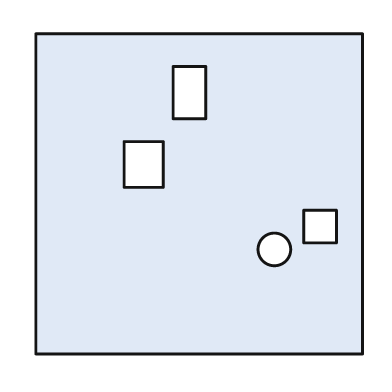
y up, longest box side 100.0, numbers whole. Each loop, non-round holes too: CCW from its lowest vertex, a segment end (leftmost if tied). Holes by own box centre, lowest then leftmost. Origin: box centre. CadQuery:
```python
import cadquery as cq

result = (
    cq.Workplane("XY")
    .moveTo(-50.0, -49.0)
    .lineTo(50.0, -49.0)
    .lineTo(50.0, 49.0)
    .lineTo(-50.0, 49.0)
    .close()
    .moveTo(23.0, -17.0)
    .circle(5.0)
    .moveTo(32.0, -15.0)
    .lineTo(42.0, -15.0)
    .lineTo(42.0, -5.0)
    .lineTo(32.0, -5.0)
    .close()
    .moveTo(-23.0, 2.0)
    .lineTo(-11.0, 2.0)
    .lineTo(-11.0, 16.0)
    .lineTo(-23.0, 16.0)
    .close()
    .moveTo(-8.0, 23.0)
    .lineTo(2.0, 23.0)
    .lineTo(2.0, 39.0)
    .lineTo(-8.0, 39.0)
    .close()
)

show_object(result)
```